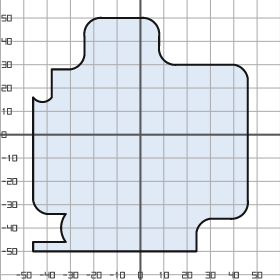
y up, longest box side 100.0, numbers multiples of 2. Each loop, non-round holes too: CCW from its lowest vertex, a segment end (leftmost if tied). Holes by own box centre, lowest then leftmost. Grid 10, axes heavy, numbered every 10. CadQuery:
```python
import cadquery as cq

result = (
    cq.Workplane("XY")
    .moveTo(-46.0, -50.0)
    .lineTo(24.0, -50.0)
    .lineTo(24.0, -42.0)
    .threePointArc((26.0, -38.0), (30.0, -36.0))
    .lineTo(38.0, -36.0)
    .threePointArc((44.0, -34.0), (46.0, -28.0))
    .lineTo(46.0, 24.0)
    .threePointArc((44.0, 28.0), (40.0, 30.0))
    .lineTo(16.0, 30.0)
    .threePointArc((10.0, 32.0), (8.0, 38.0))
    .lineTo(8.0, 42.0)
    .threePointArc((6.0, 48.0), (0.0, 50.0))
    .lineTo(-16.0, 50.0)
    .threePointArc((-22.0, 48.0), (-24.0, 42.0))
    .lineTo(-24.0, 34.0)
    .threePointArc((-26.0, 30.0), (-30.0, 28.0))
    .lineTo(-38.0, 28.0)
    .lineTo(-38.0, 16.0)
    .threePointArc((-42.0, 14.0), (-46.0, 16.0))
    .lineTo(-46.0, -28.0)
    .threePointArc((-44.0, -32.0), (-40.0, -34.0))
    .lineTo(-32.0, -34.0)
    .threePointArc((-34.0, -40.0), (-32.0, -46.0))
    .lineTo(-46.0, -46.0)
    .close()
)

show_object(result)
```